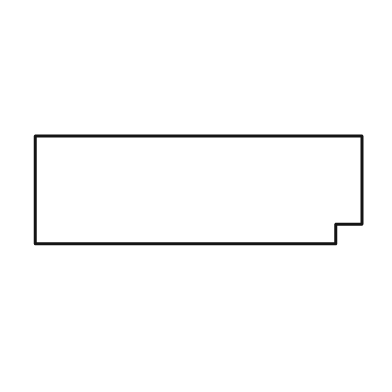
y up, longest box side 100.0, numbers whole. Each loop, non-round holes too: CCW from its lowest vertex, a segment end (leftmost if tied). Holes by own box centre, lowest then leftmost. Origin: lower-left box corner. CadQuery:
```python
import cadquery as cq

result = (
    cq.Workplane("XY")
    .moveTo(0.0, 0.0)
    .lineTo(92.0, 0.0)
    .lineTo(92.0, 6.0)
    .lineTo(100.0, 6.0)
    .lineTo(100.0, 33.0)
    .lineTo(0.0, 33.0)
    .close()
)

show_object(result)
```